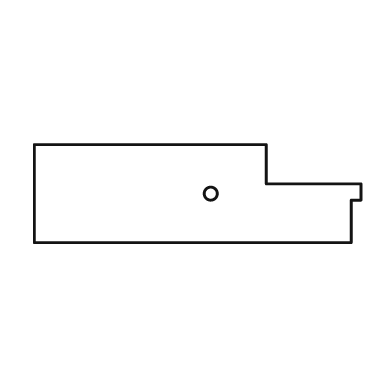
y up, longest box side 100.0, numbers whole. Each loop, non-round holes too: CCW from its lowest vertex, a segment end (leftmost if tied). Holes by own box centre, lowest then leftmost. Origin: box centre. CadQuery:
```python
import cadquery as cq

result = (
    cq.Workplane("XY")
    .moveTo(-50.0, -15.0)
    .lineTo(47.0, -15.0)
    .lineTo(47.0, -2.0)
    .lineTo(50.0, -2.0)
    .lineTo(50.0, 3.0)
    .lineTo(21.0, 3.0)
    .lineTo(21.0, 15.0)
    .lineTo(-50.0, 15.0)
    .close()
    .moveTo(4.0, 0.0)
    .circle(2.0)
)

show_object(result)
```